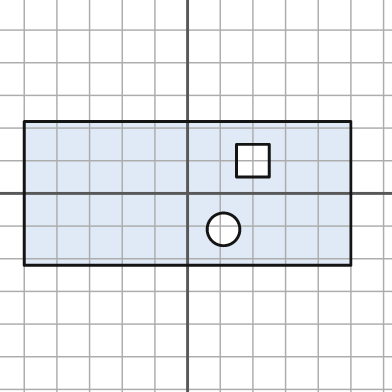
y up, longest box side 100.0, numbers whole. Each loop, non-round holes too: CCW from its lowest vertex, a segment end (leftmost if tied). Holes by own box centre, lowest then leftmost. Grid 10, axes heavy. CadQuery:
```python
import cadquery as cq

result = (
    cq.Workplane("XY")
    .moveTo(-50.0, -22.0)
    .lineTo(50.0, -22.0)
    .lineTo(50.0, 22.0)
    .lineTo(-50.0, 22.0)
    .close()
    .moveTo(11.0, -11.0)
    .circle(5.0)
    .moveTo(15.0, 5.0)
    .lineTo(25.0, 5.0)
    .lineTo(25.0, 15.0)
    .lineTo(15.0, 15.0)
    .close()
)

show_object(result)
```